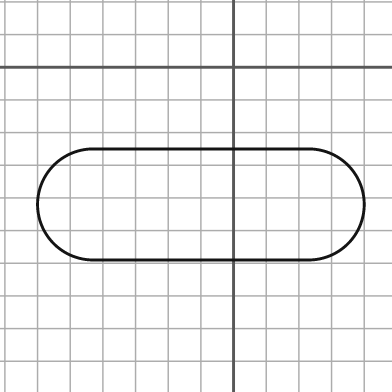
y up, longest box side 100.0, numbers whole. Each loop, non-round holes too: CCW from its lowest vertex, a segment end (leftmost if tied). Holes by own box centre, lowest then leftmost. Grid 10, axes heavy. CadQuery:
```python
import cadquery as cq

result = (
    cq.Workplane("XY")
    .moveTo(-43.0, -59.0)
    .lineTo(23.0, -59.0)
    .threePointArc((40.0, -42.0), (23.0, -25.0))
    .lineTo(-43.0, -25.0)
    .threePointArc((-60.0, -42.0), (-43.0, -59.0))
    .close()
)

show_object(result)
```